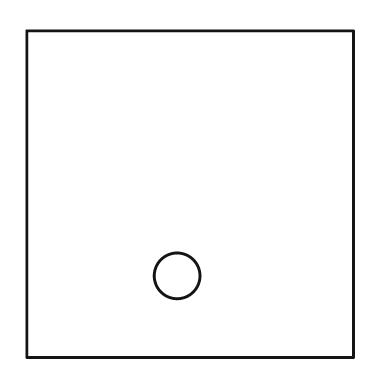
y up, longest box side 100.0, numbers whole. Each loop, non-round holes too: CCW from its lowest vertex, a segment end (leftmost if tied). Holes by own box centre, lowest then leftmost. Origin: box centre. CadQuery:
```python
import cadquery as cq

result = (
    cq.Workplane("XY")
    .moveTo(-50.0, -50.0)
    .lineTo(50.0, -50.0)
    .lineTo(50.0, 50.0)
    .lineTo(-50.0, 50.0)
    .close()
    .moveTo(-4.0, -25.0)
    .circle(7.0)
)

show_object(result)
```